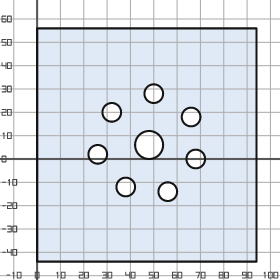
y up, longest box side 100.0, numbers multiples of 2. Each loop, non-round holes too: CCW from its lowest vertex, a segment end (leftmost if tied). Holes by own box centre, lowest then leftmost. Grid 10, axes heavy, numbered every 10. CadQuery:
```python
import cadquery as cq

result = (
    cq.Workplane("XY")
    .moveTo(0.0, -44.0)
    .lineTo(94.0, -44.0)
    .lineTo(94.0, 56.0)
    .lineTo(0.0, 56.0)
    .close()
    .moveTo(56.0, -14.0)
    .circle(4.0)
    .moveTo(38.0, -12.0)
    .circle(4.0)
    .moveTo(68.0, 0.0)
    .circle(4.0)
    .moveTo(26.0, 2.0)
    .circle(4.0)
    .moveTo(48.0, 6.0)
    .circle(6.0)
    .moveTo(66.0, 18.0)
    .circle(4.0)
    .moveTo(32.0, 20.0)
    .circle(4.0)
    .moveTo(50.0, 28.0)
    .circle(4.0)
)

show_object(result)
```